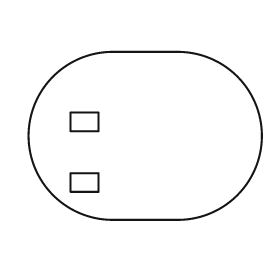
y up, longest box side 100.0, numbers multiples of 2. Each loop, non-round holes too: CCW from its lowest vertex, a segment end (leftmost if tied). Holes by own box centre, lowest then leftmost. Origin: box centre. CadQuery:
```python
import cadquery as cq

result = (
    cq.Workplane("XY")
    .moveTo(-14.0, -36.0)
    .lineTo(14.0, -36.0)
    .threePointArc((50.0, 0.0), (14.0, 36.0))
    .lineTo(-14.0, 36.0)
    .threePointArc((-50.0, 0.0), (-14.0, -36.0))
    .close()
    .moveTo(-32.0, -24.0)
    .lineTo(-20.0, -24.0)
    .lineTo(-20.0, -16.0)
    .lineTo(-32.0, -16.0)
    .close()
    .moveTo(-32.0, 2.0)
    .lineTo(-20.0, 2.0)
    .lineTo(-20.0, 10.0)
    .lineTo(-32.0, 10.0)
    .close()
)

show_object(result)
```